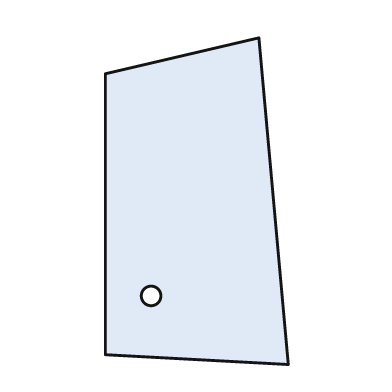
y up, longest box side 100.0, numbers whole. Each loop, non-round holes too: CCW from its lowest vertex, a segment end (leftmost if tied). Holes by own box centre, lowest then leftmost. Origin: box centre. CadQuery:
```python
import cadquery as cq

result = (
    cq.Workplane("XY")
    .moveTo(28.0, -50.0)
    .lineTo(19.0, 50.0)
    .lineTo(-28.0, 39.0)
    .lineTo(-28.0, -47.0)
    .close()
    .moveTo(-14.0, -29.0)
    .circle(3.0)
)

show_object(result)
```